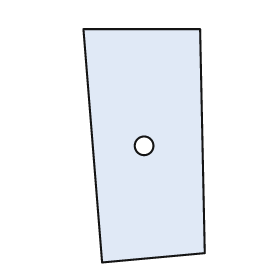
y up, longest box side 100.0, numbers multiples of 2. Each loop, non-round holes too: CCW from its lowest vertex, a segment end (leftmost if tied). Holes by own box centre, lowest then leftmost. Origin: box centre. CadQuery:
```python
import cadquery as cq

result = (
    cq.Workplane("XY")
    .moveTo(-18.0, -50.0)
    .lineTo(26.0, -46.0)
    .lineTo(24.0, 50.0)
    .lineTo(-26.0, 50.0)
    .close()
    .moveTo(0.0, 0.0)
    .circle(4.0)
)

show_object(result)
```